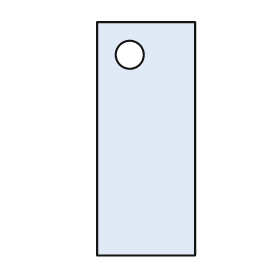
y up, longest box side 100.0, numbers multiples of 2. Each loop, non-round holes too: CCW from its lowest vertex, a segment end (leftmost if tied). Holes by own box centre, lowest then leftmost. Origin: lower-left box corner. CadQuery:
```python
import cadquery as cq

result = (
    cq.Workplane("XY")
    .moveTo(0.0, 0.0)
    .lineTo(42.0, 0.0)
    .lineTo(42.0, 100.0)
    .lineTo(0.0, 100.0)
    .close()
    .moveTo(14.0, 86.0)
    .circle(6.0)
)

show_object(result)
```